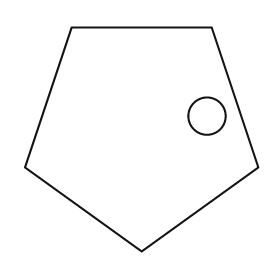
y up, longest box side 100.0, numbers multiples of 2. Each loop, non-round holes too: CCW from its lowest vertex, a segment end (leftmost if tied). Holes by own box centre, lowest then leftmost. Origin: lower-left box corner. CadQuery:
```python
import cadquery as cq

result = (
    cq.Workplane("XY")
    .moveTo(50.0, 0.0)
    .lineTo(100.0, 36.0)
    .lineTo(80.0, 96.0)
    .lineTo(20.0, 96.0)
    .lineTo(0.0, 36.0)
    .close()
    .moveTo(78.0, 58.0)
    .circle(8.0)
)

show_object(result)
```